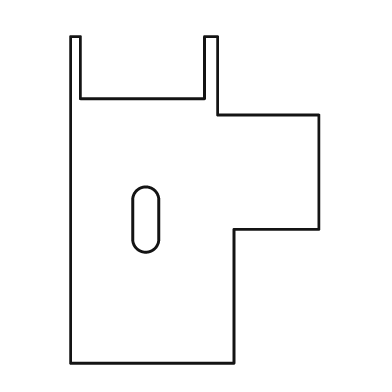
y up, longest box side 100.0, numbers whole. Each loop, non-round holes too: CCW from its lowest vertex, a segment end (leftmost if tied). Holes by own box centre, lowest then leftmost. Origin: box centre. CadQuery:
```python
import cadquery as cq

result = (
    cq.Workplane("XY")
    .moveTo(-38.0, -50.0)
    .lineTo(12.0, -50.0)
    .lineTo(12.0, -9.0)
    .lineTo(38.0, -9.0)
    .lineTo(38.0, 26.0)
    .lineTo(7.0, 26.0)
    .lineTo(7.0, 50.0)
    .lineTo(3.0, 50.0)
    .lineTo(3.0, 31.0)
    .lineTo(-35.0, 31.0)
    .lineTo(-35.0, 50.0)
    .lineTo(-38.0, 50.0)
    .close()
    .moveTo(-19.0, -12.0)
    .threePointArc((-15.0, -16.0), (-11.0, -12.0))
    .lineTo(-11.0, 0.0)
    .threePointArc((-15.0, 4.0), (-19.0, 0.0))
    .close()
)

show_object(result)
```